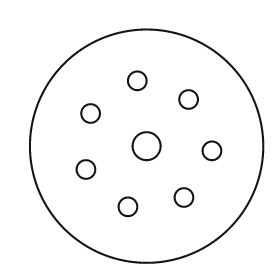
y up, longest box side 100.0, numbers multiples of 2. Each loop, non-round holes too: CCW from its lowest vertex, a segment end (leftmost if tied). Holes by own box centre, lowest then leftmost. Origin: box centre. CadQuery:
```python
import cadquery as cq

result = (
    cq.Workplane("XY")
    .moveTo(0.0, 0.0)
    .circle(50.0)
    .moveTo(-8.0, -26.0)
    .circle(4.0)
    .moveTo(16.0, -22.0)
    .circle(4.0)
    .moveTo(-26.0, -10.0)
    .circle(4.0)
    .moveTo(28.0, -2.0)
    .circle(4.0)
    .moveTo(0.0, 0.0)
    .circle(6.0)
    .moveTo(-24.0, 14.0)
    .circle(4.0)
    .moveTo(18.0, 20.0)
    .circle(4.0)
    .moveTo(-4.0, 28.0)
    .circle(4.0)
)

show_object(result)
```